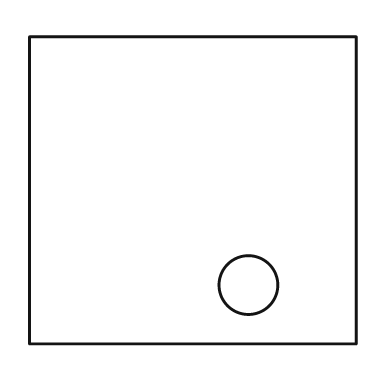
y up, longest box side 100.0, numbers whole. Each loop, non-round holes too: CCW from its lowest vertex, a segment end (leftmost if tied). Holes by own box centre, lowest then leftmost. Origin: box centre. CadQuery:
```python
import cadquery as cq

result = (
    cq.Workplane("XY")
    .moveTo(-50.0, -47.0)
    .lineTo(50.0, -47.0)
    .lineTo(50.0, 47.0)
    .lineTo(-50.0, 47.0)
    .close()
    .moveTo(17.0, -29.0)
    .circle(9.0)
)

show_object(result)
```